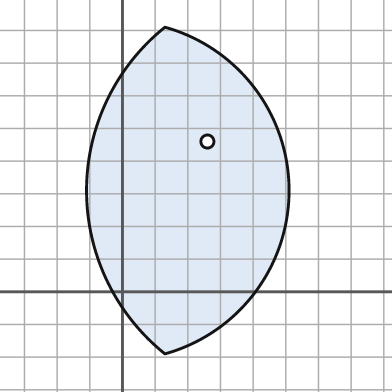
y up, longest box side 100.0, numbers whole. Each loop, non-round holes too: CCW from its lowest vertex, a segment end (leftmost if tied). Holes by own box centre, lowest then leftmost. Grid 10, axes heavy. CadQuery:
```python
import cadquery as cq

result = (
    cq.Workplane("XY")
    .moveTo(13.0, -19.0)
    .threePointArc((51.0, 31.0), (13.0, 81.0))
    .threePointArc((-11.0, 31.0), (13.0, -19.0))
    .close()
    .moveTo(26.0, 46.0)
    .circle(2.0)
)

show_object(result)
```